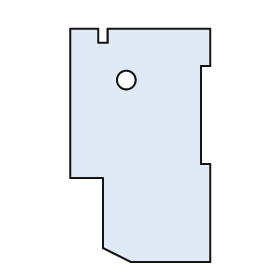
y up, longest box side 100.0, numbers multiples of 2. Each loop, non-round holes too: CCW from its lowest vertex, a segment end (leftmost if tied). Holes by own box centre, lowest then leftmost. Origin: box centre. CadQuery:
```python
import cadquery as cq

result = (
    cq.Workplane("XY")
    .moveTo(-4.0, -50.0)
    .lineTo(30.0, -50.0)
    .lineTo(30.0, -8.0)
    .lineTo(26.0, -8.0)
    .lineTo(26.0, 34.0)
    .lineTo(30.0, 34.0)
    .lineTo(30.0, 50.0)
    .lineTo(-14.0, 50.0)
    .lineTo(-14.0, 44.0)
    .lineTo(-18.0, 44.0)
    .lineTo(-18.0, 50.0)
    .lineTo(-30.0, 50.0)
    .lineTo(-30.0, -14.0)
    .lineTo(-16.0, -14.0)
    .lineTo(-16.0, -44.0)
    .close()
    .moveTo(-6.0, 28.0)
    .circle(4.0)
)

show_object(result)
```